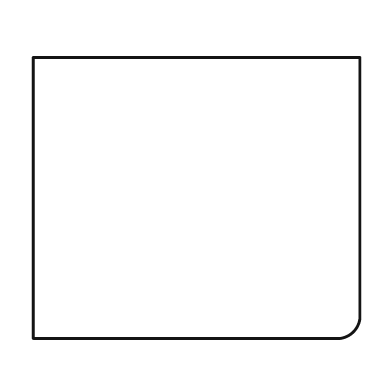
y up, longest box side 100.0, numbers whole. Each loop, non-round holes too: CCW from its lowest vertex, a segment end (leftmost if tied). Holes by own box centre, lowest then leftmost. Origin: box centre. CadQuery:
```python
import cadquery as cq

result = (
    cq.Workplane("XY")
    .moveTo(-50.0, -43.0)
    .lineTo(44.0, -43.0)
    .threePointArc((48.0, -41.0), (50.0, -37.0))
    .lineTo(50.0, 43.0)
    .lineTo(-50.0, 43.0)
    .close()
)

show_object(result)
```